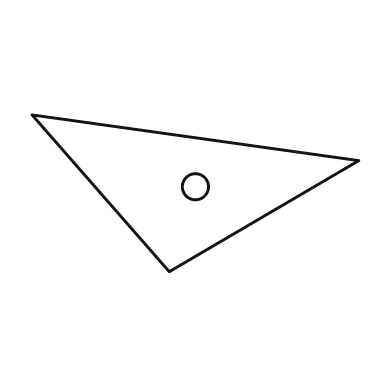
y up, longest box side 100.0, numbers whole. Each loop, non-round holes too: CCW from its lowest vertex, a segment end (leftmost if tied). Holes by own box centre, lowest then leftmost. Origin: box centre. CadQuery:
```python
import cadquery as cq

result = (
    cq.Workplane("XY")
    .moveTo(-8.0, -24.0)
    .lineTo(50.0, 10.0)
    .lineTo(-50.0, 24.0)
    .close()
    .moveTo(0.0, 2.0)
    .circle(4.0)
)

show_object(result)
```